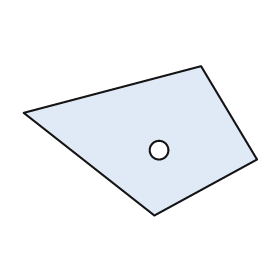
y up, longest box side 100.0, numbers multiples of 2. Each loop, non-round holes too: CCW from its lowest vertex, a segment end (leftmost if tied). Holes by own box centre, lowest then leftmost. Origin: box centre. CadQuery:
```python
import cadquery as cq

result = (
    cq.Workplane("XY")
    .moveTo(6.0, -32.0)
    .lineTo(50.0, -8.0)
    .lineTo(26.0, 32.0)
    .lineTo(-50.0, 12.0)
    .close()
    .moveTo(8.0, -4.0)
    .circle(4.0)
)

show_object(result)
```